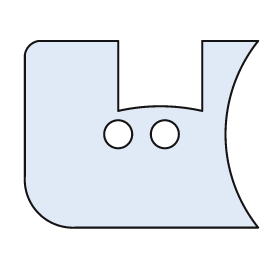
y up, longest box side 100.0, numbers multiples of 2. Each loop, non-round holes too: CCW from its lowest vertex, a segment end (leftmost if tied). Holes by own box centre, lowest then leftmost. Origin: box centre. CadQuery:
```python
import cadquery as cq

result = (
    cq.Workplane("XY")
    .moveTo(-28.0, -40.0)
    .lineTo(50.0, -40.0)
    .threePointArc((36.0, 0.0), (50.0, 40.0))
    .lineTo(26.0, 40.0)
    .lineTo(26.0, 10.0)
    .threePointArc((8.0, 12.0), (-10.0, 10.0))
    .lineTo(-10.0, 40.0)
    .lineTo(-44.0, 40.0)
    .threePointArc((-48.0, 38.0), (-50.0, 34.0))
    .lineTo(-50.0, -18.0)
    .threePointArc((-44.0, -34.0), (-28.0, -40.0))
    .close()
    .moveTo(-10.0, 0.0)
    .circle(6.0)
    .moveTo(10.0, 0.0)
    .circle(6.0)
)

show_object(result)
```